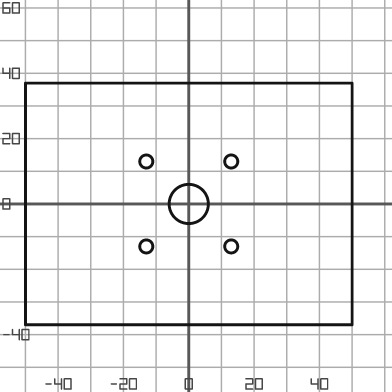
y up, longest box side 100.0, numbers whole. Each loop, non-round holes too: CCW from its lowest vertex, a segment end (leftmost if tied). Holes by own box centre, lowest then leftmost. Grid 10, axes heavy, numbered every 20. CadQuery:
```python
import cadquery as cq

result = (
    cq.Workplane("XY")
    .moveTo(-50.0, -37.0)
    .lineTo(50.0, -37.0)
    .lineTo(50.0, 37.0)
    .lineTo(-50.0, 37.0)
    .close()
    .moveTo(-13.0, -13.0)
    .circle(2.0)
    .moveTo(13.0, -13.0)
    .circle(2.0)
    .moveTo(0.0, 0.0)
    .circle(6.0)
    .moveTo(-13.0, 13.0)
    .circle(2.0)
    .moveTo(13.0, 13.0)
    .circle(2.0)
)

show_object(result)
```